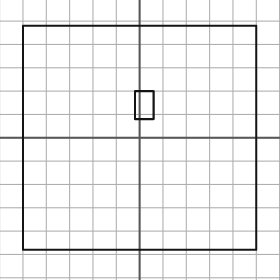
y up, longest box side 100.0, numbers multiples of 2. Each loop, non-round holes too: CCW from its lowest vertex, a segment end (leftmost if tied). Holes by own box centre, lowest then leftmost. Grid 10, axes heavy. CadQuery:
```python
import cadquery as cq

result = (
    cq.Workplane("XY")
    .moveTo(-50.0, -48.0)
    .lineTo(50.0, -48.0)
    .lineTo(50.0, 48.0)
    .lineTo(-50.0, 48.0)
    .close()
    .moveTo(-2.0, 8.0)
    .lineTo(6.0, 8.0)
    .lineTo(6.0, 20.0)
    .lineTo(-2.0, 20.0)
    .close()
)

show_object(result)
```